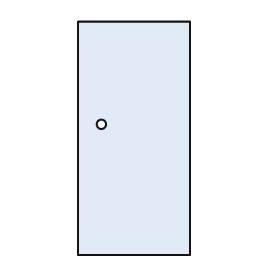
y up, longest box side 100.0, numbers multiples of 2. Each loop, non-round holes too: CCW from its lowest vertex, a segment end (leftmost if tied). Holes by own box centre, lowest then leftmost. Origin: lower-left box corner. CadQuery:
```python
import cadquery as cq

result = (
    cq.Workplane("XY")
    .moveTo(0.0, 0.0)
    .lineTo(48.0, 0.0)
    .lineTo(48.0, 100.0)
    .lineTo(0.0, 100.0)
    .close()
    .moveTo(10.0, 56.0)
    .circle(2.0)
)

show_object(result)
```